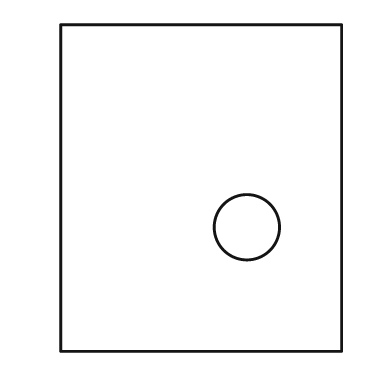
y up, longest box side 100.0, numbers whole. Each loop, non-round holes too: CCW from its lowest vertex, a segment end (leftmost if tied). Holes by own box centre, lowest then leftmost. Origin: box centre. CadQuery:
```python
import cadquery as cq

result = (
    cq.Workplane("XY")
    .moveTo(-43.0, -50.0)
    .lineTo(43.0, -50.0)
    .lineTo(43.0, 50.0)
    .lineTo(-43.0, 50.0)
    .close()
    .moveTo(14.0, -12.0)
    .circle(10.0)
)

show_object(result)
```